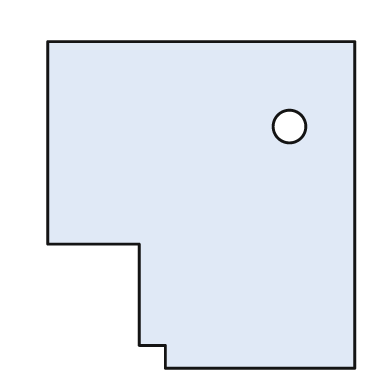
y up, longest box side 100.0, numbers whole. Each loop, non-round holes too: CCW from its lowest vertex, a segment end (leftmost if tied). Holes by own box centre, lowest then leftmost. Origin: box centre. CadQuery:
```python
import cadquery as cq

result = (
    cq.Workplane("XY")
    .moveTo(-11.0, -50.0)
    .lineTo(47.0, -50.0)
    .lineTo(47.0, 50.0)
    .lineTo(-47.0, 50.0)
    .lineTo(-47.0, -12.0)
    .lineTo(-19.0, -12.0)
    .lineTo(-19.0, -43.0)
    .lineTo(-11.0, -43.0)
    .close()
    .moveTo(27.0, 24.0)
    .circle(5.0)
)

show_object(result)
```